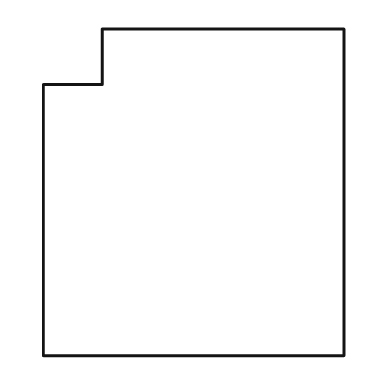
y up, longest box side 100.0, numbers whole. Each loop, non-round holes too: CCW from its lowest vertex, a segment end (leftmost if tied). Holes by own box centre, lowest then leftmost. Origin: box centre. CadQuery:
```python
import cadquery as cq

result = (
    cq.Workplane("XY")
    .moveTo(-46.0, -50.0)
    .lineTo(46.0, -50.0)
    .lineTo(46.0, 50.0)
    .lineTo(-28.0, 50.0)
    .lineTo(-28.0, 33.0)
    .lineTo(-46.0, 33.0)
    .close()
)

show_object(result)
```